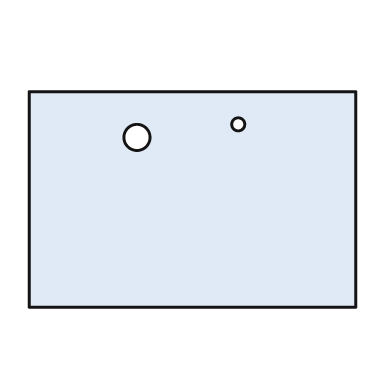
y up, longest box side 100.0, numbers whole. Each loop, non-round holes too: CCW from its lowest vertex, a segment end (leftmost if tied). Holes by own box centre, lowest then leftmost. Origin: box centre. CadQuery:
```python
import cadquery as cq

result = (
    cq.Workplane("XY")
    .moveTo(-50.0, -33.0)
    .lineTo(50.0, -33.0)
    .lineTo(50.0, 33.0)
    .lineTo(-50.0, 33.0)
    .close()
    .moveTo(-17.0, 19.0)
    .circle(4.0)
    .moveTo(14.0, 23.0)
    .circle(2.0)
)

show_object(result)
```